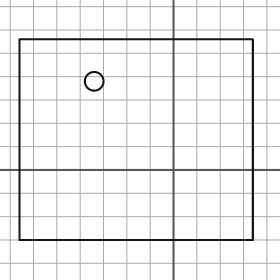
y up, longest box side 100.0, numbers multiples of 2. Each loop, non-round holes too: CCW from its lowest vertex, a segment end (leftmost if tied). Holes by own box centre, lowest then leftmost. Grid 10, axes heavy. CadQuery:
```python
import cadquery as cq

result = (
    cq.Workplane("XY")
    .moveTo(-66.0, -30.0)
    .lineTo(34.0, -30.0)
    .lineTo(34.0, 56.0)
    .lineTo(-66.0, 56.0)
    .close()
    .moveTo(-34.0, 38.0)
    .circle(4.0)
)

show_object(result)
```